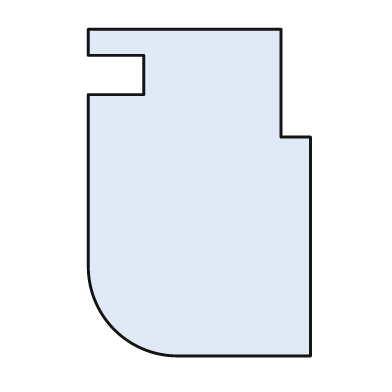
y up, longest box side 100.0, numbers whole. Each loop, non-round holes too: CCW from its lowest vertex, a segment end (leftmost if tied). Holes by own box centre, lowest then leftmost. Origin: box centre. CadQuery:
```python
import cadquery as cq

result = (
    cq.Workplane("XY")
    .moveTo(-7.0, -50.0)
    .lineTo(34.0, -50.0)
    .lineTo(34.0, 17.0)
    .lineTo(25.0, 17.0)
    .lineTo(25.0, 50.0)
    .lineTo(-34.0, 50.0)
    .lineTo(-34.0, 42.0)
    .lineTo(-17.0, 42.0)
    .lineTo(-17.0, 30.0)
    .lineTo(-34.0, 30.0)
    .lineTo(-34.0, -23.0)
    .threePointArc((-26.0, -42.0), (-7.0, -50.0))
    .close()
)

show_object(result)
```